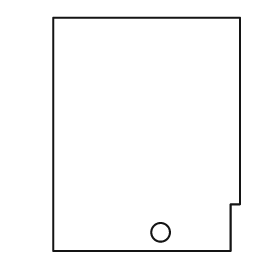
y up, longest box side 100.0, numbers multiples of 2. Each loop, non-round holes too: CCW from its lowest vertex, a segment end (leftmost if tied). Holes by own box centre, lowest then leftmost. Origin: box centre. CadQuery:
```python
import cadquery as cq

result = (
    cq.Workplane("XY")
    .moveTo(-40.0, -50.0)
    .lineTo(36.0, -50.0)
    .lineTo(36.0, -30.0)
    .lineTo(40.0, -30.0)
    .lineTo(40.0, 50.0)
    .lineTo(-40.0, 50.0)
    .close()
    .moveTo(6.0, -42.0)
    .circle(4.0)
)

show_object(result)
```